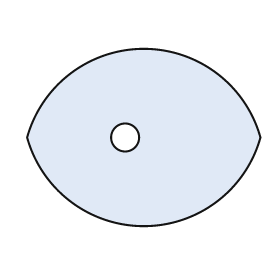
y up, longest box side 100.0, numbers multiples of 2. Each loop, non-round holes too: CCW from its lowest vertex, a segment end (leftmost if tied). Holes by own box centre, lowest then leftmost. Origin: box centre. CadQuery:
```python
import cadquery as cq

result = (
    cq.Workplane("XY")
    .moveTo(-50.0, 0.0)
    .threePointArc((0.0, -38.0), (50.0, 0.0))
    .threePointArc((0.0, 38.0), (-50.0, 0.0))
    .close()
    .moveTo(-8.0, 0.0)
    .circle(6.0)
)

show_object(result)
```